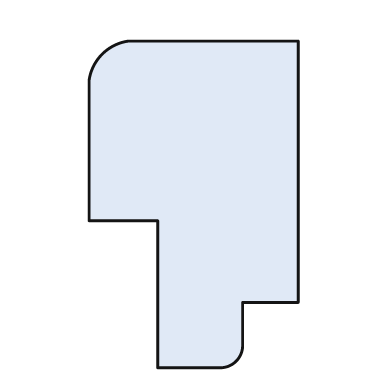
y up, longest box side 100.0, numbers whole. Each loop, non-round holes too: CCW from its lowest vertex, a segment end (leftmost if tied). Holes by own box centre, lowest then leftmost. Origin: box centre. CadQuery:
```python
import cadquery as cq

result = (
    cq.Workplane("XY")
    .moveTo(-11.0, -50.0)
    .lineTo(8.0, -50.0)
    .threePointArc((13.0, -48.0), (15.0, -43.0))
    .lineTo(15.0, -30.0)
    .lineTo(32.0, -30.0)
    .lineTo(32.0, 50.0)
    .lineTo(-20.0, 50.0)
    .threePointArc((-28.0, 46.0), (-32.0, 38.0))
    .lineTo(-32.0, -5.0)
    .lineTo(-11.0, -5.0)
    .close()
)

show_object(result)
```